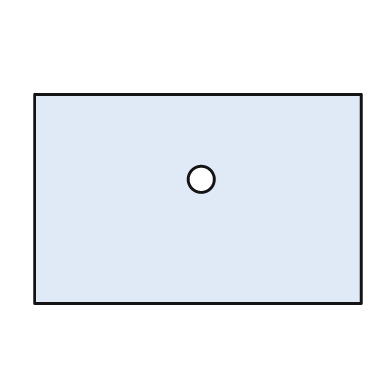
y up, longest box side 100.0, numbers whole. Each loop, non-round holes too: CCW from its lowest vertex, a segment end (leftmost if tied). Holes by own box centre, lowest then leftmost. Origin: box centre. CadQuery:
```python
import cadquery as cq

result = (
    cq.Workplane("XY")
    .moveTo(-50.0, -32.0)
    .lineTo(50.0, -32.0)
    .lineTo(50.0, 32.0)
    .lineTo(-50.0, 32.0)
    .close()
    .moveTo(1.0, 6.0)
    .circle(4.0)
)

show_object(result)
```